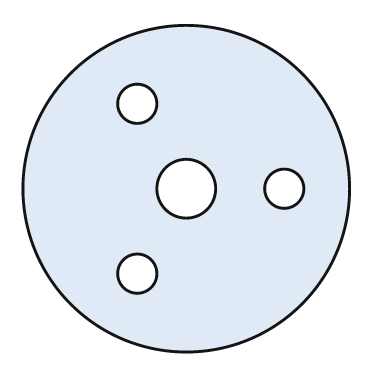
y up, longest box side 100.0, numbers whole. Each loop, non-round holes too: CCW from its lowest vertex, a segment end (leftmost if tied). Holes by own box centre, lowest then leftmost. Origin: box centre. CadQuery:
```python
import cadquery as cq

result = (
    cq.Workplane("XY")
    .moveTo(0.0, 0.0)
    .circle(50.0)
    .moveTo(-15.0, -26.0)
    .circle(6.0)
    .moveTo(0.0, 0.0)
    .circle(9.0)
    .moveTo(30.0, 0.0)
    .circle(6.0)
    .moveTo(-15.0, 26.0)
    .circle(6.0)
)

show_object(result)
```